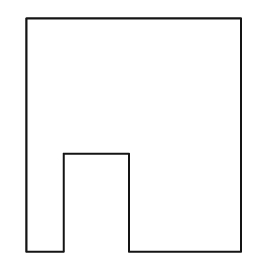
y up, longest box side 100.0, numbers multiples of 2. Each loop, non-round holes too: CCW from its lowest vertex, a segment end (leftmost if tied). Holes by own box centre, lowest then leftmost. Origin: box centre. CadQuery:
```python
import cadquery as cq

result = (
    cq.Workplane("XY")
    .moveTo(-46.0, -50.0)
    .lineTo(-30.0, -50.0)
    .lineTo(-30.0, -8.0)
    .lineTo(-2.0, -8.0)
    .lineTo(-2.0, -50.0)
    .lineTo(46.0, -50.0)
    .lineTo(46.0, 50.0)
    .lineTo(-46.0, 50.0)
    .close()
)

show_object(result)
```